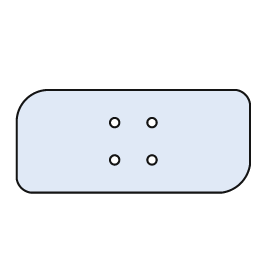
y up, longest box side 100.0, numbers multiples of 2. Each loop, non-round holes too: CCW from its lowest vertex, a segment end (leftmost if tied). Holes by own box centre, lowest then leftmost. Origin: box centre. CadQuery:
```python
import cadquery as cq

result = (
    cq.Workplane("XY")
    .moveTo(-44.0, -22.0)
    .lineTo(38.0, -22.0)
    .threePointArc((46.0, -18.0), (50.0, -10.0))
    .lineTo(50.0, 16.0)
    .threePointArc((48.0, 20.0), (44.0, 22.0))
    .lineTo(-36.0, 22.0)
    .threePointArc((-46.0, 18.0), (-50.0, 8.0))
    .lineTo(-50.0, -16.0)
    .threePointArc((-48.0, -20.0), (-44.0, -22.0))
    .close()
    .moveTo(-8.0, -8.0)
    .circle(2.0)
    .moveTo(8.0, -8.0)
    .circle(2.0)
    .moveTo(-8.0, 8.0)
    .circle(2.0)
    .moveTo(8.0, 8.0)
    .circle(2.0)
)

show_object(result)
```